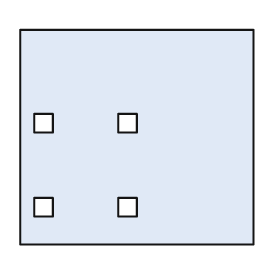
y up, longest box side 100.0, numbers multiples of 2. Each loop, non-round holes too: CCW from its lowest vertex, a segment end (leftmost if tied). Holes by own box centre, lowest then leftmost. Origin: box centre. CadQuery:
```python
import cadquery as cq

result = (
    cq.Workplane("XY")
    .moveTo(-50.0, -46.0)
    .lineTo(50.0, -46.0)
    .lineTo(50.0, 46.0)
    .lineTo(-50.0, 46.0)
    .close()
    .moveTo(-44.0, -34.0)
    .lineTo(-36.0, -34.0)
    .lineTo(-36.0, -26.0)
    .lineTo(-44.0, -26.0)
    .close()
    .moveTo(-8.0, -34.0)
    .lineTo(0.0, -34.0)
    .lineTo(0.0, -26.0)
    .lineTo(-8.0, -26.0)
    .close()
    .moveTo(-44.0, 2.0)
    .lineTo(-36.0, 2.0)
    .lineTo(-36.0, 10.0)
    .lineTo(-44.0, 10.0)
    .close()
    .moveTo(-8.0, 2.0)
    .lineTo(0.0, 2.0)
    .lineTo(0.0, 10.0)
    .lineTo(-8.0, 10.0)
    .close()
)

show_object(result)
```